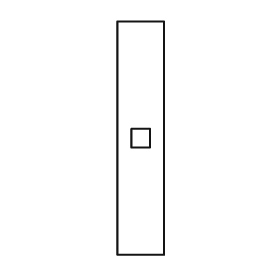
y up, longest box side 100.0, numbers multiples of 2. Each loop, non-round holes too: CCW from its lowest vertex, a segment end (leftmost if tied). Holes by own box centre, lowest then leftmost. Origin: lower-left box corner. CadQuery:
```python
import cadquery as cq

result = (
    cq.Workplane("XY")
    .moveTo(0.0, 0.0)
    .lineTo(20.0, 0.0)
    .lineTo(20.0, 100.0)
    .lineTo(0.0, 100.0)
    .close()
    .moveTo(6.0, 46.0)
    .lineTo(14.0, 46.0)
    .lineTo(14.0, 54.0)
    .lineTo(6.0, 54.0)
    .close()
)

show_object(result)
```